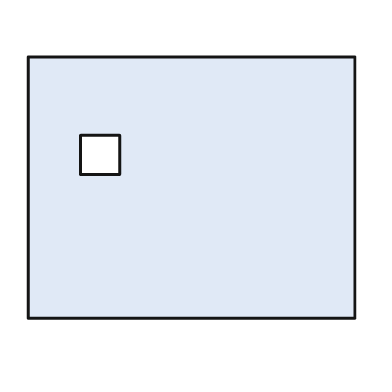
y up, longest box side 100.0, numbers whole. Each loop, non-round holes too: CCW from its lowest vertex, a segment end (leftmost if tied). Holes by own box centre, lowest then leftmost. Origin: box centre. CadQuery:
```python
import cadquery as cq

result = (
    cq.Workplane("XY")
    .moveTo(-50.0, -40.0)
    .lineTo(50.0, -40.0)
    .lineTo(50.0, 40.0)
    .lineTo(-50.0, 40.0)
    .close()
    .moveTo(-34.0, 4.0)
    .lineTo(-22.0, 4.0)
    .lineTo(-22.0, 16.0)
    .lineTo(-34.0, 16.0)
    .close()
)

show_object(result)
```